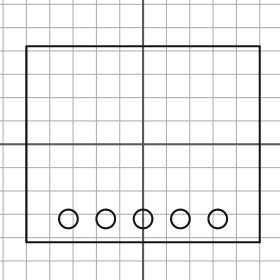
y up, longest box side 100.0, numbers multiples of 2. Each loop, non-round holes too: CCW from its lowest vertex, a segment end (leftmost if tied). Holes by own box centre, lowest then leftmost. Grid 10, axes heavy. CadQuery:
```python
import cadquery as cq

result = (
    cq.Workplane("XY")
    .moveTo(-50.0, -42.0)
    .lineTo(50.0, -42.0)
    .lineTo(50.0, 42.0)
    .lineTo(-50.0, 42.0)
    .close()
    .moveTo(-32.0, -32.0)
    .circle(4.0)
    .moveTo(-16.0, -32.0)
    .circle(4.0)
    .moveTo(0.0, -32.0)
    .circle(4.0)
    .moveTo(16.0, -32.0)
    .circle(4.0)
    .moveTo(32.0, -32.0)
    .circle(4.0)
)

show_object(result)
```